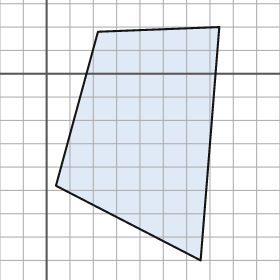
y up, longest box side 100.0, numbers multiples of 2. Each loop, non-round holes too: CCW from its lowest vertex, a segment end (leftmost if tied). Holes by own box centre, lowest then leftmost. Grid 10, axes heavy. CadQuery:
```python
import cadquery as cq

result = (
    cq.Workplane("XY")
    .moveTo(66.0, -80.0)
    .lineTo(74.0, 20.0)
    .lineTo(22.0, 18.0)
    .lineTo(4.0, -48.0)
    .close()
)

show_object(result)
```